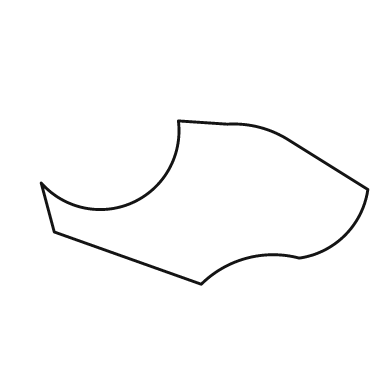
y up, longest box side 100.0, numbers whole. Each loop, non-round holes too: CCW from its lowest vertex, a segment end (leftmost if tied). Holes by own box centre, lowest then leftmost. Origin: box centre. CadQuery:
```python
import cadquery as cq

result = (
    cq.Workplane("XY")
    .moveTo(-1.0, -25.0)
    .threePointArc((13.0, -17.0), (29.0, -17.0))
    .threePointArc((43.0, -10.0), (50.0, 4.0))
    .lineTo(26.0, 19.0)
    .threePointArc((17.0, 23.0), (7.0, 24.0))
    .lineTo(-8.0, 25.0)
    .threePointArc((-22.0, 0.0), (-50.0, 6.0))
    .lineTo(-46.0, -9.0)
    .close()
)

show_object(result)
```